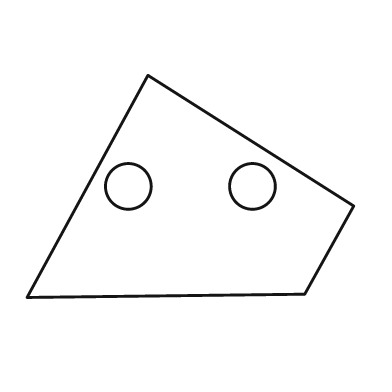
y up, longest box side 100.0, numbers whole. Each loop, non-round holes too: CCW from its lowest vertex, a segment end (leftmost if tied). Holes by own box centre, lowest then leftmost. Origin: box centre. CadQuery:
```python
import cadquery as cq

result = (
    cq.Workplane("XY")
    .moveTo(-50.0, -34.0)
    .lineTo(35.0, -33.0)
    .lineTo(50.0, -6.0)
    .lineTo(-13.0, 34.0)
    .close()
    .moveTo(-19.0, 0.0)
    .circle(7.0)
    .moveTo(19.0, 0.0)
    .circle(7.0)
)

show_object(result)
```